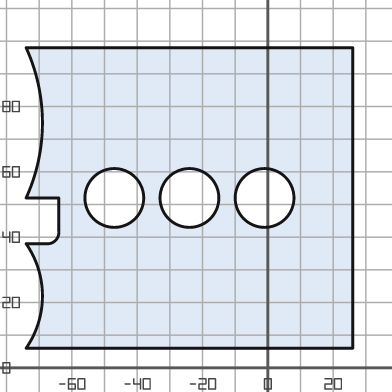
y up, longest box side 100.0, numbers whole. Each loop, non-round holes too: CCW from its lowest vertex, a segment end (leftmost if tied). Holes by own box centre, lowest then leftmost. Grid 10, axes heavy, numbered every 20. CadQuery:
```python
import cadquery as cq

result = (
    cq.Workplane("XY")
    .moveTo(-74.0, 6.0)
    .lineTo(26.0, 6.0)
    .lineTo(26.0, 98.0)
    .lineTo(-74.0, 98.0)
    .threePointArc((-69.0, 75.0), (-74.0, 52.0))
    .lineTo(-64.0, 52.0)
    .lineTo(-64.0, 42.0)
    .threePointArc((-65.0, 39.0), (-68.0, 38.0))
    .lineTo(-74.0, 38.0)
    .threePointArc((-69.0, 22.0), (-74.0, 6.0))
    .close()
    .moveTo(-47.0, 52.0)
    .circle(9.0)
    .moveTo(-24.0, 52.0)
    .circle(9.0)
    .moveTo(-1.0, 52.0)
    .circle(9.0)
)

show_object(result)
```